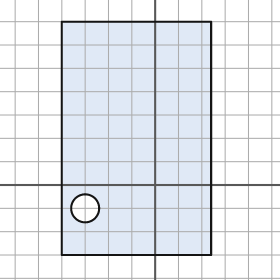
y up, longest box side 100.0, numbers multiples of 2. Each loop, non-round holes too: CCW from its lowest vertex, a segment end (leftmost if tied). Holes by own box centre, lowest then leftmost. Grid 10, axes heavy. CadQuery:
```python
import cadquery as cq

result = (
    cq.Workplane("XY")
    .moveTo(-40.0, -30.0)
    .lineTo(24.0, -30.0)
    .lineTo(24.0, 70.0)
    .lineTo(-40.0, 70.0)
    .close()
    .moveTo(-30.0, -10.0)
    .circle(6.0)
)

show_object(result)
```